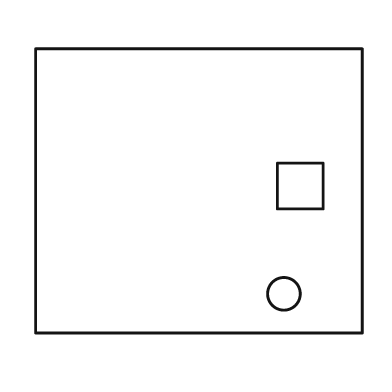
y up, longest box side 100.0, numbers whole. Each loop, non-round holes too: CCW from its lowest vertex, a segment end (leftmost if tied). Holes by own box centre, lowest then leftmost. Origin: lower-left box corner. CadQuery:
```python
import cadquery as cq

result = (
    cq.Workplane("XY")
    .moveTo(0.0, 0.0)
    .lineTo(100.0, 0.0)
    .lineTo(100.0, 87.0)
    .lineTo(0.0, 87.0)
    .close()
    .moveTo(76.0, 12.0)
    .circle(5.0)
    .moveTo(74.0, 38.0)
    .lineTo(88.0, 38.0)
    .lineTo(88.0, 52.0)
    .lineTo(74.0, 52.0)
    .close()
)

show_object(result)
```